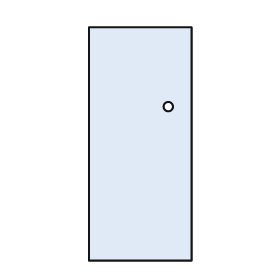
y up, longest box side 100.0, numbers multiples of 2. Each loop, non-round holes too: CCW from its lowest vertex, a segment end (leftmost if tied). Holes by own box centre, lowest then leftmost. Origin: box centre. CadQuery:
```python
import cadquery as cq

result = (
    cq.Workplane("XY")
    .moveTo(-22.0, -50.0)
    .lineTo(22.0, -50.0)
    .lineTo(22.0, 50.0)
    .lineTo(-22.0, 50.0)
    .close()
    .moveTo(12.0, 16.0)
    .circle(2.0)
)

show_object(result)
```